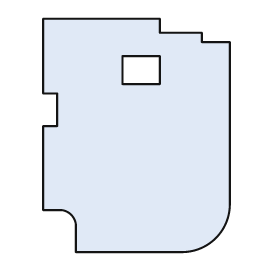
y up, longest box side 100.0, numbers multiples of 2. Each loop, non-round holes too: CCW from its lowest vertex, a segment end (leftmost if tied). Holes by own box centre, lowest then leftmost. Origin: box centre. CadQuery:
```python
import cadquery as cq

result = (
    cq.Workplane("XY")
    .moveTo(-26.0, -50.0)
    .lineTo(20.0, -50.0)
    .threePointArc((34.0, -44.0), (40.0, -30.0))
    .lineTo(40.0, 40.0)
    .lineTo(28.0, 40.0)
    .lineTo(28.0, 44.0)
    .lineTo(10.0, 44.0)
    .lineTo(10.0, 50.0)
    .lineTo(-40.0, 50.0)
    .lineTo(-40.0, 18.0)
    .lineTo(-34.0, 18.0)
    .lineTo(-34.0, 4.0)
    .lineTo(-40.0, 4.0)
    .lineTo(-40.0, -32.0)
    .lineTo(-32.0, -32.0)
    .threePointArc((-28.0, -34.0), (-26.0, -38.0))
    .close()
    .moveTo(-6.0, 22.0)
    .lineTo(10.0, 22.0)
    .lineTo(10.0, 34.0)
    .lineTo(-6.0, 34.0)
    .close()
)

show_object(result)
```